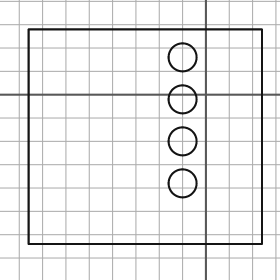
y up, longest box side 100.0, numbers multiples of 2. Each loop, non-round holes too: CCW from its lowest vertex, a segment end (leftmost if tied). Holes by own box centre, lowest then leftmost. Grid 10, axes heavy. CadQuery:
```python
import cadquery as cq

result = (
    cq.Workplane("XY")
    .moveTo(-76.0, -64.0)
    .lineTo(24.0, -64.0)
    .lineTo(24.0, 28.0)
    .lineTo(-76.0, 28.0)
    .close()
    .moveTo(-10.0, -38.0)
    .circle(6.0)
    .moveTo(-10.0, -20.0)
    .circle(6.0)
    .moveTo(-10.0, -2.0)
    .circle(6.0)
    .moveTo(-10.0, 16.0)
    .circle(6.0)
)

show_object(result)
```